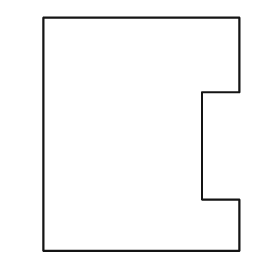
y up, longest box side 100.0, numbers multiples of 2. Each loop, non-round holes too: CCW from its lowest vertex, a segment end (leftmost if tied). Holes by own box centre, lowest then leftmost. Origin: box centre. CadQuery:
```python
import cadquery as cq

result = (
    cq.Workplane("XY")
    .moveTo(-42.0, -50.0)
    .lineTo(42.0, -50.0)
    .lineTo(42.0, -28.0)
    .lineTo(26.0, -28.0)
    .lineTo(26.0, 18.0)
    .lineTo(42.0, 18.0)
    .lineTo(42.0, 50.0)
    .lineTo(-42.0, 50.0)
    .close()
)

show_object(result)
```